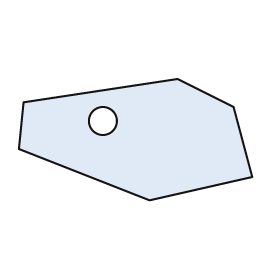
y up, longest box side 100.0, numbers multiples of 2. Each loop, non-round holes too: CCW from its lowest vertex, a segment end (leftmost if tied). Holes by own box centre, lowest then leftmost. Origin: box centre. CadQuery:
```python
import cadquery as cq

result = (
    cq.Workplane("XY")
    .moveTo(6.0, -26.0)
    .lineTo(50.0, -16.0)
    .lineTo(42.0, 14.0)
    .lineTo(18.0, 26.0)
    .lineTo(-48.0, 16.0)
    .lineTo(-50.0, -4.0)
    .close()
    .moveTo(-14.0, 8.0)
    .circle(6.0)
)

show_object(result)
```